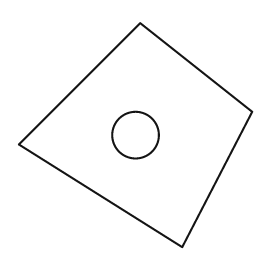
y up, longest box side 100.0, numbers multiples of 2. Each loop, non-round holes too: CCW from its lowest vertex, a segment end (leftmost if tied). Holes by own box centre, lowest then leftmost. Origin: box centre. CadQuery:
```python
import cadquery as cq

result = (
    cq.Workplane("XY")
    .moveTo(20.0, -48.0)
    .lineTo(50.0, 10.0)
    .lineTo(2.0, 48.0)
    .lineTo(-50.0, -4.0)
    .close()
    .moveTo(0.0, 0.0)
    .circle(10.0)
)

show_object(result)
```